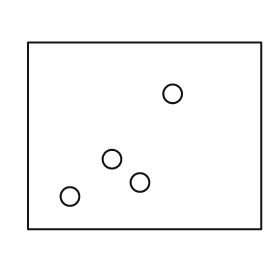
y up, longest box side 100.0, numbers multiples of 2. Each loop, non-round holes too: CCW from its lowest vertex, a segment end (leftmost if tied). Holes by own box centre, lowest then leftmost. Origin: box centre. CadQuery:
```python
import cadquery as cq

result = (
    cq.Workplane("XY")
    .moveTo(-50.0, -40.0)
    .lineTo(50.0, -40.0)
    .lineTo(50.0, 40.0)
    .lineTo(-50.0, 40.0)
    .close()
    .moveTo(-32.0, -26.0)
    .circle(4.0)
    .moveTo(-2.0, -20.0)
    .circle(4.0)
    .moveTo(-14.0, -10.0)
    .circle(4.0)
    .moveTo(12.0, 18.0)
    .circle(4.0)
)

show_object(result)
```